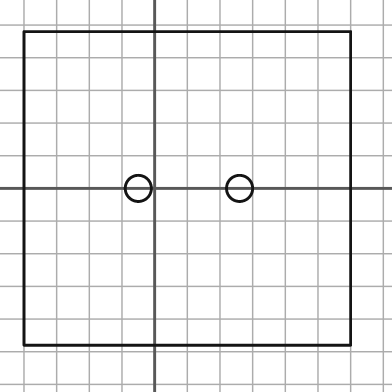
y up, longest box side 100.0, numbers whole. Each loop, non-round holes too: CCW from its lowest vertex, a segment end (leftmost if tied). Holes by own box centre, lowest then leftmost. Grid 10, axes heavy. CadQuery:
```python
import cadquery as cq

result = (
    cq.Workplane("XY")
    .moveTo(-40.0, -48.0)
    .lineTo(60.0, -48.0)
    .lineTo(60.0, 48.0)
    .lineTo(-40.0, 48.0)
    .close()
    .moveTo(-5.0, 0.0)
    .circle(4.0)
    .moveTo(26.0, 0.0)
    .circle(4.0)
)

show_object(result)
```